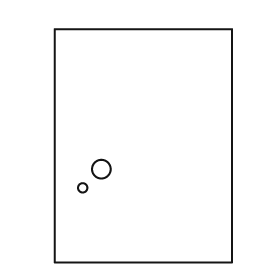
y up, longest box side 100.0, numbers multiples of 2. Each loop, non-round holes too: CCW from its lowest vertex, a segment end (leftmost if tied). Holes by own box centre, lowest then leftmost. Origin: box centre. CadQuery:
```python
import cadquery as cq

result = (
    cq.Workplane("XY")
    .moveTo(-38.0, -50.0)
    .lineTo(38.0, -50.0)
    .lineTo(38.0, 50.0)
    .lineTo(-38.0, 50.0)
    .close()
    .moveTo(-26.0, -18.0)
    .circle(2.0)
    .moveTo(-18.0, -10.0)
    .circle(4.0)
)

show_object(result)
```